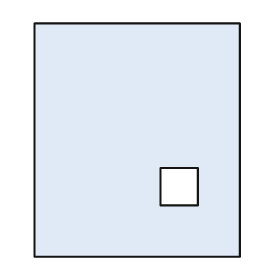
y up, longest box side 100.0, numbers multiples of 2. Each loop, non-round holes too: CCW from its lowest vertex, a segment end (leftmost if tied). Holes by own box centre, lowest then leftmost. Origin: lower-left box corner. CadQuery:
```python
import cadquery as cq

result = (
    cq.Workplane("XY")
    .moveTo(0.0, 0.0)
    .lineTo(88.0, 0.0)
    .lineTo(88.0, 100.0)
    .lineTo(0.0, 100.0)
    .close()
    .moveTo(54.0, 22.0)
    .lineTo(70.0, 22.0)
    .lineTo(70.0, 38.0)
    .lineTo(54.0, 38.0)
    .close()
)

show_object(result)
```